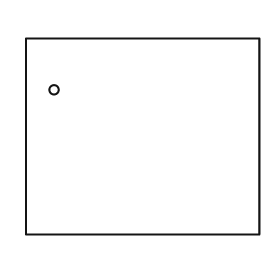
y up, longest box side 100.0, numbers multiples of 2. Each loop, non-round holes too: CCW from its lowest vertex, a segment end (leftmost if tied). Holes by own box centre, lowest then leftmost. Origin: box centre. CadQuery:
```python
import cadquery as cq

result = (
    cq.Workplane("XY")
    .moveTo(-50.0, -42.0)
    .lineTo(50.0, -42.0)
    .lineTo(50.0, 42.0)
    .lineTo(-50.0, 42.0)
    .close()
    .moveTo(-38.0, 20.0)
    .circle(2.0)
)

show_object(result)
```